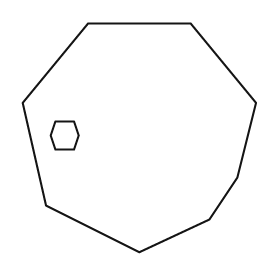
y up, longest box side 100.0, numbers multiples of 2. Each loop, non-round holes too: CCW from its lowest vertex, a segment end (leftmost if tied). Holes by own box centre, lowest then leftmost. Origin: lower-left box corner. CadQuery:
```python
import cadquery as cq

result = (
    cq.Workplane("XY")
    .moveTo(50.0, 0.0)
    .lineTo(80.0, 14.0)
    .lineTo(92.0, 32.0)
    .lineTo(100.0, 64.0)
    .lineTo(72.0, 98.0)
    .lineTo(28.0, 98.0)
    .lineTo(0.0, 64.0)
    .lineTo(10.0, 20.0)
    .close()
    .moveTo(14.0, 44.0)
    .lineTo(22.0, 44.0)
    .lineTo(24.0, 50.0)
    .lineTo(22.0, 56.0)
    .lineTo(14.0, 56.0)
    .lineTo(12.0, 50.0)
    .close()
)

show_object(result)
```